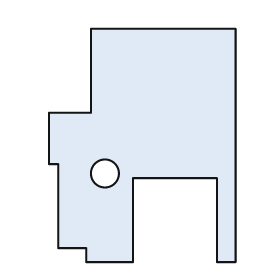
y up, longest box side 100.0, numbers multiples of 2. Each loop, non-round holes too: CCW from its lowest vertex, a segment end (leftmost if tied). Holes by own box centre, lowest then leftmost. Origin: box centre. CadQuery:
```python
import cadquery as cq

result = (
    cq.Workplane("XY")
    .moveTo(-24.0, -50.0)
    .lineTo(-4.0, -50.0)
    .lineTo(-4.0, -14.0)
    .lineTo(32.0, -14.0)
    .lineTo(32.0, -50.0)
    .lineTo(40.0, -50.0)
    .lineTo(40.0, 50.0)
    .lineTo(-22.0, 50.0)
    .lineTo(-22.0, 14.0)
    .lineTo(-40.0, 14.0)
    .lineTo(-40.0, -8.0)
    .lineTo(-36.0, -8.0)
    .lineTo(-36.0, -44.0)
    .lineTo(-24.0, -44.0)
    .close()
    .moveTo(-16.0, -12.0)
    .circle(6.0)
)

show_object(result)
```